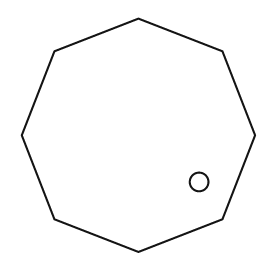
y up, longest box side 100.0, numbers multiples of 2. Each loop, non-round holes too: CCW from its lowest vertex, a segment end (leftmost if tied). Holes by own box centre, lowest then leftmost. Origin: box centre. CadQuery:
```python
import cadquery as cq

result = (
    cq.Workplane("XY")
    .moveTo(0.0, -50.0)
    .lineTo(36.0, -36.0)
    .lineTo(50.0, 0.0)
    .lineTo(36.0, 36.0)
    .lineTo(0.0, 50.0)
    .lineTo(-36.0, 36.0)
    .lineTo(-50.0, 0.0)
    .lineTo(-36.0, -36.0)
    .close()
    .moveTo(26.0, -20.0)
    .circle(4.0)
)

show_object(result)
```